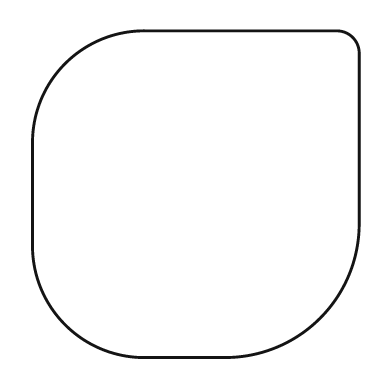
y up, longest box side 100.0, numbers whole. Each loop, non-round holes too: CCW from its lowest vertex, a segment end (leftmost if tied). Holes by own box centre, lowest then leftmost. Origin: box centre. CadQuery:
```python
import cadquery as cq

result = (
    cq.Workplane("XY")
    .moveTo(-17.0, -50.0)
    .lineTo(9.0, -50.0)
    .threePointArc((38.0, -38.0), (50.0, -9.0))
    .lineTo(50.0, 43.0)
    .threePointArc((48.0, 48.0), (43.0, 50.0))
    .lineTo(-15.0, 50.0)
    .threePointArc((-40.0, 40.0), (-50.0, 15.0))
    .lineTo(-50.0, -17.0)
    .threePointArc((-40.0, -40.0), (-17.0, -50.0))
    .close()
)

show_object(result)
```